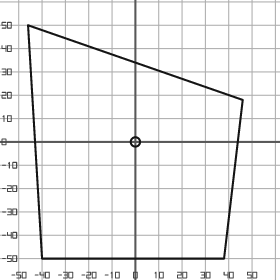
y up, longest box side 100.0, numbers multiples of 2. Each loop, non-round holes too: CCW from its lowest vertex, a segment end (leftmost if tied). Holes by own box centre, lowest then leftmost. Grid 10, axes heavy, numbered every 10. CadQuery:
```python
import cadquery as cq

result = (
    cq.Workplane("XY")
    .moveTo(-40.0, -50.0)
    .lineTo(38.0, -50.0)
    .lineTo(46.0, 18.0)
    .lineTo(-46.0, 50.0)
    .close()
    .moveTo(0.0, 0.0)
    .circle(2.0)
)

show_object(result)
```